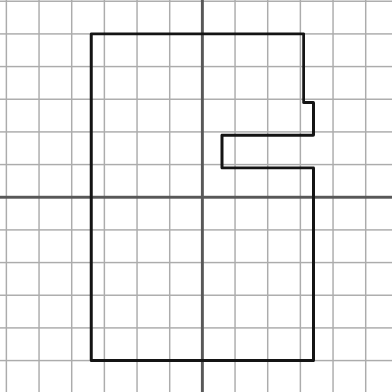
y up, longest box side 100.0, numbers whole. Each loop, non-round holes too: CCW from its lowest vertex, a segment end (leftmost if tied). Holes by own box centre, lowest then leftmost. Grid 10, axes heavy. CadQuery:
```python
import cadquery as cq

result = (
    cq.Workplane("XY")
    .moveTo(-34.0, -50.0)
    .lineTo(34.0, -50.0)
    .lineTo(34.0, 9.0)
    .lineTo(6.0, 9.0)
    .lineTo(6.0, 19.0)
    .lineTo(34.0, 19.0)
    .lineTo(34.0, 29.0)
    .lineTo(31.0, 29.0)
    .lineTo(31.0, 50.0)
    .lineTo(-34.0, 50.0)
    .close()
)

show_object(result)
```